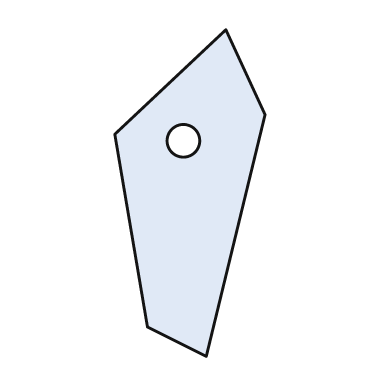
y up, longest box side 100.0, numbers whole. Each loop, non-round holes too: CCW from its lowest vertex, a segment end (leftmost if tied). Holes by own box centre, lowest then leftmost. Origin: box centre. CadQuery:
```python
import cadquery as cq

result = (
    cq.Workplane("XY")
    .moveTo(5.0, -50.0)
    .lineTo(23.0, 24.0)
    .lineTo(11.0, 50.0)
    .lineTo(-23.0, 18.0)
    .lineTo(-13.0, -41.0)
    .close()
    .moveTo(-2.0, 16.0)
    .circle(5.0)
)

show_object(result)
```